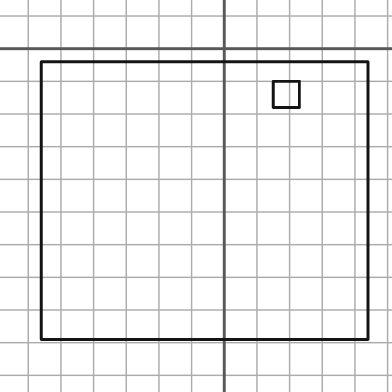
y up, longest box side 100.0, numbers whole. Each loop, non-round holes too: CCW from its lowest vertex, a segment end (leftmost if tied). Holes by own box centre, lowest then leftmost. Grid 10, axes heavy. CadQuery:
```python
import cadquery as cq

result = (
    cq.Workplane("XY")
    .moveTo(-56.0, -89.0)
    .lineTo(44.0, -89.0)
    .lineTo(44.0, -4.0)
    .lineTo(-56.0, -4.0)
    .close()
    .moveTo(15.0, -18.0)
    .lineTo(23.0, -18.0)
    .lineTo(23.0, -10.0)
    .lineTo(15.0, -10.0)
    .close()
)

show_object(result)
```